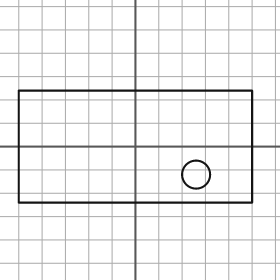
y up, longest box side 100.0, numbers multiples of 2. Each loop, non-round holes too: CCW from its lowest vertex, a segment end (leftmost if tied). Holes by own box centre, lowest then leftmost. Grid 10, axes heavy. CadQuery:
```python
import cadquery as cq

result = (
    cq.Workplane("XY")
    .moveTo(-50.0, -24.0)
    .lineTo(50.0, -24.0)
    .lineTo(50.0, 24.0)
    .lineTo(-50.0, 24.0)
    .close()
    .moveTo(26.0, -12.0)
    .circle(6.0)
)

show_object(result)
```